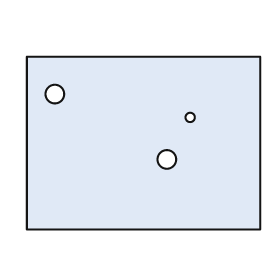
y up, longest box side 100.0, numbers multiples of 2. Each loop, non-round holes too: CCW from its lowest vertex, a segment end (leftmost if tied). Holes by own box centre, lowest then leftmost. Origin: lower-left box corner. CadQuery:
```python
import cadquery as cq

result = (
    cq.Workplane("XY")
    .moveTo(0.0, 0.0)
    .lineTo(100.0, 0.0)
    .lineTo(100.0, 74.0)
    .lineTo(0.0, 74.0)
    .close()
    .moveTo(60.0, 30.0)
    .circle(4.0)
    .moveTo(70.0, 48.0)
    .circle(2.0)
    .moveTo(12.0, 58.0)
    .circle(4.0)
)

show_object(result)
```